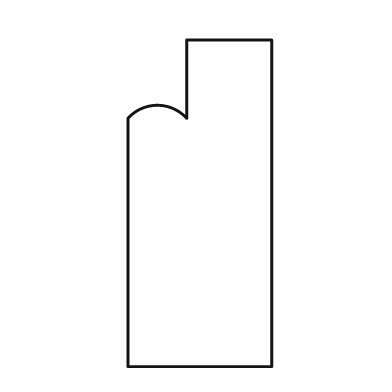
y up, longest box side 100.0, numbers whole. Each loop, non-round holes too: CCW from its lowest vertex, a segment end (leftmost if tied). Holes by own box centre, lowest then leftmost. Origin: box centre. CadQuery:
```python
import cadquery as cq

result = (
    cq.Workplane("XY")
    .moveTo(-22.0, -50.0)
    .lineTo(22.0, -50.0)
    .lineTo(22.0, 50.0)
    .lineTo(-4.0, 50.0)
    .lineTo(-4.0, 26.0)
    .threePointArc((-13.0, 30.0), (-22.0, 26.0))
    .close()
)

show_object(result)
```